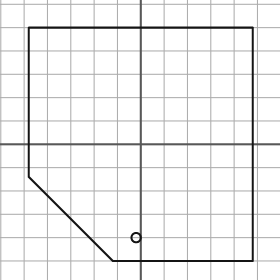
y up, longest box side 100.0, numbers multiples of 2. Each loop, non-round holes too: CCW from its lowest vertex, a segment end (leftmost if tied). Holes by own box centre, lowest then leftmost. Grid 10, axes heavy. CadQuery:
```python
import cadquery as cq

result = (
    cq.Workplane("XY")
    .moveTo(-12.0, -50.0)
    .lineTo(48.0, -50.0)
    .lineTo(48.0, 50.0)
    .lineTo(-48.0, 50.0)
    .lineTo(-48.0, -14.0)
    .close()
    .moveTo(-2.0, -40.0)
    .circle(2.0)
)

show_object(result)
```